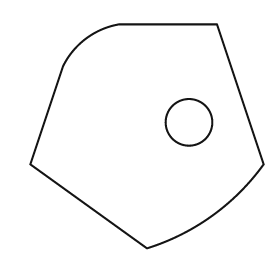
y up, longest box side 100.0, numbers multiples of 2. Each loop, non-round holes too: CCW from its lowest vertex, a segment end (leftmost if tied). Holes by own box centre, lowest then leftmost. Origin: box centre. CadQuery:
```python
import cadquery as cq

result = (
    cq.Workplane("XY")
    .moveTo(0.0, -48.0)
    .threePointArc((28.0, -34.0), (50.0, -12.0))
    .lineTo(30.0, 48.0)
    .lineTo(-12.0, 48.0)
    .threePointArc((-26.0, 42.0), (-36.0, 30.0))
    .lineTo(-50.0, -12.0)
    .close()
    .moveTo(18.0, 6.0)
    .circle(10.0)
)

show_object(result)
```